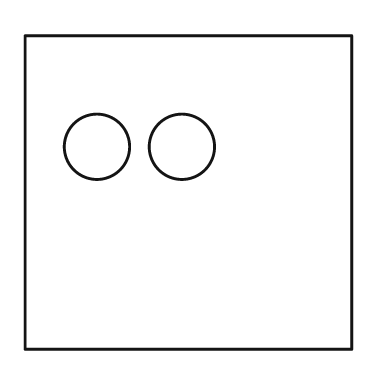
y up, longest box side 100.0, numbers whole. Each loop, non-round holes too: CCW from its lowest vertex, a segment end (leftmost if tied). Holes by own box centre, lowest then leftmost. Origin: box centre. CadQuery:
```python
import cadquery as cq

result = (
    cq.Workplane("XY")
    .moveTo(-50.0, -48.0)
    .lineTo(50.0, -48.0)
    .lineTo(50.0, 48.0)
    .lineTo(-50.0, 48.0)
    .close()
    .moveTo(-28.0, 14.0)
    .circle(10.0)
    .moveTo(-2.0, 14.0)
    .circle(10.0)
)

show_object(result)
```